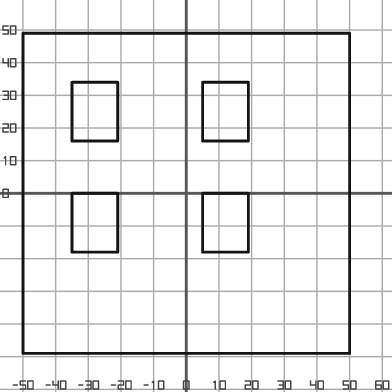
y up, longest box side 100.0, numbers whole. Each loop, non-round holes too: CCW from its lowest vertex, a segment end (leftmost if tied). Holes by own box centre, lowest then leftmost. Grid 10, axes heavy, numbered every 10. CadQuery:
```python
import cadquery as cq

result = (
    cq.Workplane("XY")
    .moveTo(-50.0, -49.0)
    .lineTo(50.0, -49.0)
    .lineTo(50.0, 49.0)
    .lineTo(-50.0, 49.0)
    .close()
    .moveTo(-35.0, -18.0)
    .lineTo(-21.0, -18.0)
    .lineTo(-21.0, 0.0)
    .lineTo(-35.0, 0.0)
    .close()
    .moveTo(5.0, -18.0)
    .lineTo(19.0, -18.0)
    .lineTo(19.0, 0.0)
    .lineTo(5.0, 0.0)
    .close()
    .moveTo(-35.0, 16.0)
    .lineTo(-21.0, 16.0)
    .lineTo(-21.0, 34.0)
    .lineTo(-35.0, 34.0)
    .close()
    .moveTo(5.0, 16.0)
    .lineTo(19.0, 16.0)
    .lineTo(19.0, 34.0)
    .lineTo(5.0, 34.0)
    .close()
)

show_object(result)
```